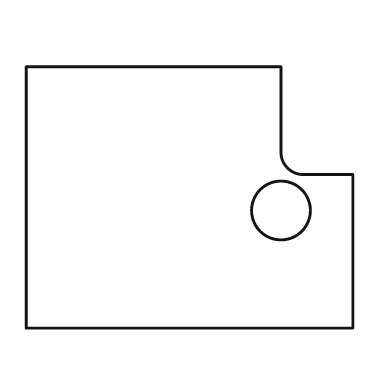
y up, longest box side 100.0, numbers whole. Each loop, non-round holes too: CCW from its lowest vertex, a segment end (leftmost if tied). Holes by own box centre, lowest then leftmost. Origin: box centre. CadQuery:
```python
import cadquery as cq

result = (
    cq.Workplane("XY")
    .moveTo(-50.0, -40.0)
    .lineTo(50.0, -40.0)
    .lineTo(50.0, 7.0)
    .lineTo(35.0, 7.0)
    .threePointArc((30.0, 9.0), (28.0, 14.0))
    .lineTo(28.0, 40.0)
    .lineTo(-50.0, 40.0)
    .close()
    .moveTo(28.0, -4.0)
    .circle(9.0)
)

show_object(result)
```